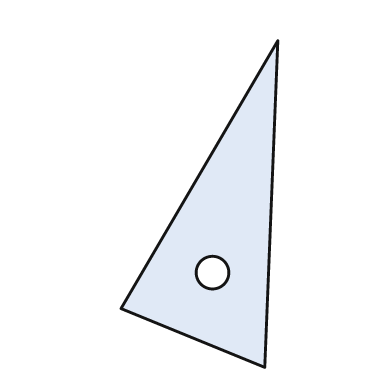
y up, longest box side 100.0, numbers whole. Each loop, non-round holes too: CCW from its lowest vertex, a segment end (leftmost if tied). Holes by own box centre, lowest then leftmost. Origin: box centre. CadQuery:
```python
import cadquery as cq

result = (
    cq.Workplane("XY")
    .moveTo(20.0, -50.0)
    .lineTo(24.0, 50.0)
    .lineTo(-24.0, -32.0)
    .close()
    .moveTo(4.0, -21.0)
    .circle(5.0)
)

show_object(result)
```